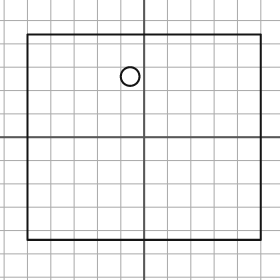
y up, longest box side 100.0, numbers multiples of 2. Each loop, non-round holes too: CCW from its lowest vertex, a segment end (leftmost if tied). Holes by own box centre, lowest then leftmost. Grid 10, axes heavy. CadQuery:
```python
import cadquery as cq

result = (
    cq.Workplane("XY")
    .moveTo(-50.0, -44.0)
    .lineTo(50.0, -44.0)
    .lineTo(50.0, 44.0)
    .lineTo(-50.0, 44.0)
    .close()
    .moveTo(-6.0, 26.0)
    .circle(4.0)
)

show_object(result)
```